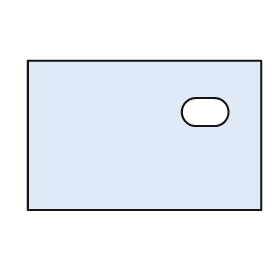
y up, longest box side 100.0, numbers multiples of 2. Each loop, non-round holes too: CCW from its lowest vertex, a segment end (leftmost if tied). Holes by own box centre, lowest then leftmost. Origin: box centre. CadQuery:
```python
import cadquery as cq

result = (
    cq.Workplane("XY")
    .moveTo(-50.0, -32.0)
    .lineTo(50.0, -32.0)
    .lineTo(50.0, 32.0)
    .lineTo(-50.0, 32.0)
    .close()
    .moveTo(22.0, 4.0)
    .lineTo(30.0, 4.0)
    .threePointArc((36.0, 10.0), (30.0, 16.0))
    .lineTo(22.0, 16.0)
    .threePointArc((16.0, 10.0), (22.0, 4.0))
    .close()
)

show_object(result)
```